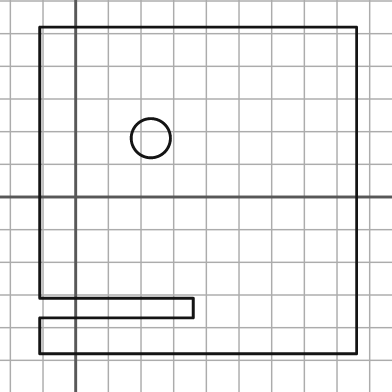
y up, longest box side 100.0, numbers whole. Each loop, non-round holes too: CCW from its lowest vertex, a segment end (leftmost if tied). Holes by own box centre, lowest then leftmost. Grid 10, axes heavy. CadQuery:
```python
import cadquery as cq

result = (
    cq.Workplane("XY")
    .moveTo(-11.0, -48.0)
    .lineTo(86.0, -48.0)
    .lineTo(86.0, 52.0)
    .lineTo(-11.0, 52.0)
    .lineTo(-11.0, -31.0)
    .lineTo(36.0, -31.0)
    .lineTo(36.0, -37.0)
    .lineTo(-11.0, -37.0)
    .close()
    .moveTo(23.0, 18.0)
    .circle(6.0)
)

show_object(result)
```